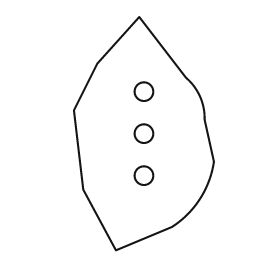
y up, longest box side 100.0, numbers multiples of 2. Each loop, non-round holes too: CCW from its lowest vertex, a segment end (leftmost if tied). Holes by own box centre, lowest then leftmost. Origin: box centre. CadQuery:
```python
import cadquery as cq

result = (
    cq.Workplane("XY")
    .moveTo(-12.0, -50.0)
    .lineTo(12.0, -40.0)
    .threePointArc((24.0, -28.0), (30.0, -12.0))
    .lineTo(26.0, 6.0)
    .threePointArc((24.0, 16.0), (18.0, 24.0))
    .lineTo(-2.0, 50.0)
    .lineTo(-20.0, 30.0)
    .lineTo(-30.0, 10.0)
    .lineTo(-26.0, -24.0)
    .close()
    .moveTo(0.0, -18.0)
    .circle(4.0)
    .moveTo(0.0, 0.0)
    .circle(4.0)
    .moveTo(0.0, 18.0)
    .circle(4.0)
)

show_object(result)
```